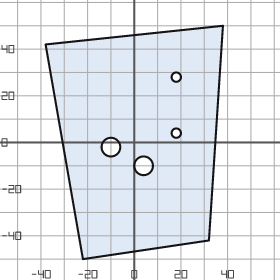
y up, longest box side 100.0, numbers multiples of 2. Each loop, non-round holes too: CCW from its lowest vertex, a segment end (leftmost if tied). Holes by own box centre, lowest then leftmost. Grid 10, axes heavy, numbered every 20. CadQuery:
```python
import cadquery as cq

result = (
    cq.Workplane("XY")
    .moveTo(-22.0, -50.0)
    .lineTo(32.0, -42.0)
    .lineTo(38.0, 50.0)
    .lineTo(-38.0, 42.0)
    .close()
    .moveTo(4.0, -10.0)
    .circle(4.0)
    .moveTo(-10.0, -2.0)
    .circle(4.0)
    .moveTo(18.0, 4.0)
    .circle(2.0)
    .moveTo(18.0, 28.0)
    .circle(2.0)
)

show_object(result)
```